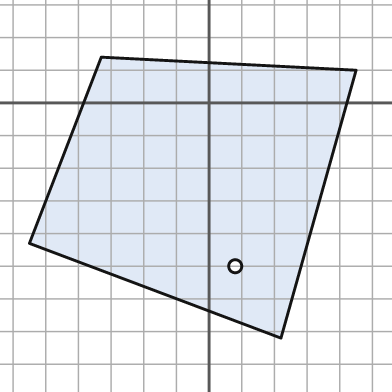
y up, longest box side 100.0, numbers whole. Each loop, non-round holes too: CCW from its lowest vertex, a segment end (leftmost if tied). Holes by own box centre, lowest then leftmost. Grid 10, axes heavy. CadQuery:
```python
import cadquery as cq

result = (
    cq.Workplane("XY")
    .moveTo(22.0, -72.0)
    .lineTo(45.0, 10.0)
    .lineTo(-33.0, 14.0)
    .lineTo(-55.0, -43.0)
    .close()
    .moveTo(8.0, -50.0)
    .circle(2.0)
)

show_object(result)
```